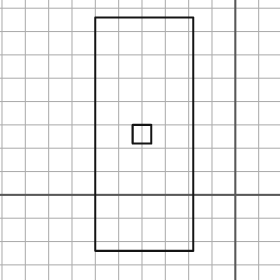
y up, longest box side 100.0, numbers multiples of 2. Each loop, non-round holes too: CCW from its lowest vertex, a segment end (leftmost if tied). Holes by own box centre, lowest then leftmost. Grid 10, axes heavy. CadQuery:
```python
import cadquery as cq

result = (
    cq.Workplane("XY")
    .moveTo(-60.0, -24.0)
    .lineTo(-18.0, -24.0)
    .lineTo(-18.0, 76.0)
    .lineTo(-60.0, 76.0)
    .close()
    .moveTo(-44.0, 22.0)
    .lineTo(-36.0, 22.0)
    .lineTo(-36.0, 30.0)
    .lineTo(-44.0, 30.0)
    .close()
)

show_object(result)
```